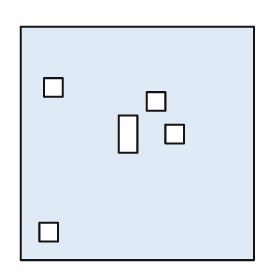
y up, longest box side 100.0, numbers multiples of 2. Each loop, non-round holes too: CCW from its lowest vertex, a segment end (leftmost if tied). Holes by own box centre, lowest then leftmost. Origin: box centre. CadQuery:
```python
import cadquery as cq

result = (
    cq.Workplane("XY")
    .moveTo(-50.0, -50.0)
    .lineTo(50.0, -50.0)
    .lineTo(50.0, 50.0)
    .lineTo(-50.0, 50.0)
    .close()
    .moveTo(-42.0, -42.0)
    .lineTo(-34.0, -42.0)
    .lineTo(-34.0, -34.0)
    .lineTo(-42.0, -34.0)
    .close()
    .moveTo(-8.0, -4.0)
    .lineTo(0.0, -4.0)
    .lineTo(0.0, 12.0)
    .lineTo(-8.0, 12.0)
    .close()
    .moveTo(12.0, 0.0)
    .lineTo(20.0, 0.0)
    .lineTo(20.0, 8.0)
    .lineTo(12.0, 8.0)
    .close()
    .moveTo(4.0, 14.0)
    .lineTo(12.0, 14.0)
    .lineTo(12.0, 22.0)
    .lineTo(4.0, 22.0)
    .close()
    .moveTo(-40.0, 20.0)
    .lineTo(-32.0, 20.0)
    .lineTo(-32.0, 28.0)
    .lineTo(-40.0, 28.0)
    .close()
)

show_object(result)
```